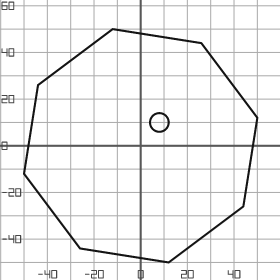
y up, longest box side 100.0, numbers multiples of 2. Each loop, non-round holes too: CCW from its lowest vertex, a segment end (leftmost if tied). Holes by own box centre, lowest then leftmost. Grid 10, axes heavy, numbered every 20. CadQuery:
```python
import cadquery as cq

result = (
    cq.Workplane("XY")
    .moveTo(12.0, -50.0)
    .lineTo(44.0, -26.0)
    .lineTo(50.0, 12.0)
    .lineTo(26.0, 44.0)
    .lineTo(-12.0, 50.0)
    .lineTo(-44.0, 26.0)
    .lineTo(-50.0, -12.0)
    .lineTo(-26.0, -44.0)
    .close()
    .moveTo(8.0, 10.0)
    .circle(4.0)
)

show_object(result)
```